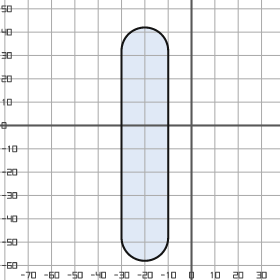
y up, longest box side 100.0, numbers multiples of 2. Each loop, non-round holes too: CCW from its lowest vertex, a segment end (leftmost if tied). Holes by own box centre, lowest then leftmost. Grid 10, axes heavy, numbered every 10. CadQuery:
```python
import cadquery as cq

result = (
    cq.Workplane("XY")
    .moveTo(-30.0, -48.0)
    .threePointArc((-20.0, -58.0), (-10.0, -48.0))
    .lineTo(-10.0, 32.0)
    .threePointArc((-20.0, 42.0), (-30.0, 32.0))
    .close()
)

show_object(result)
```